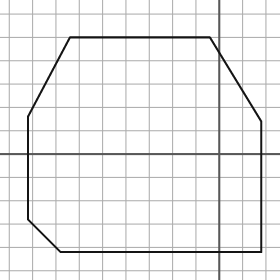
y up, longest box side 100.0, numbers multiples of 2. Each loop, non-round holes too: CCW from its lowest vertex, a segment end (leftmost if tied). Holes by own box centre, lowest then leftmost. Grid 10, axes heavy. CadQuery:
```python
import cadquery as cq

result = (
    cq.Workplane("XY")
    .moveTo(-68.0, -42.0)
    .lineTo(18.0, -42.0)
    .lineTo(18.0, 14.0)
    .lineTo(-4.0, 50.0)
    .lineTo(-64.0, 50.0)
    .lineTo(-82.0, 16.0)
    .lineTo(-82.0, -28.0)
    .close()
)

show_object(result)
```